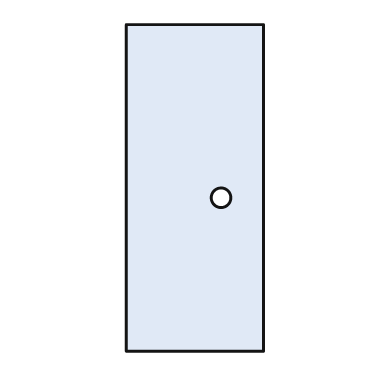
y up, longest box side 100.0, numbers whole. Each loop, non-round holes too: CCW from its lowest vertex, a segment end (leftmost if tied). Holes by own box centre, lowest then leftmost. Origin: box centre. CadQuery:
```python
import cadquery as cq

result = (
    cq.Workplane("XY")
    .moveTo(-21.0, -50.0)
    .lineTo(21.0, -50.0)
    .lineTo(21.0, 50.0)
    .lineTo(-21.0, 50.0)
    .close()
    .moveTo(8.0, -3.0)
    .circle(3.0)
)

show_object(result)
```